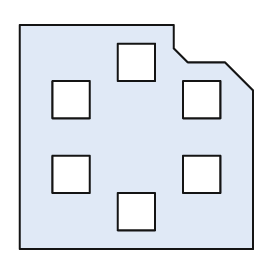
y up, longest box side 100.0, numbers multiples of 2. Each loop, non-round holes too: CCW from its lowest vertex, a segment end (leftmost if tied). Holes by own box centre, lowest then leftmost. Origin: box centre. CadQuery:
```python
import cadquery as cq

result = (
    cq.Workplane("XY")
    .moveTo(-50.0, -48.0)
    .lineTo(50.0, -48.0)
    .lineTo(50.0, 20.0)
    .lineTo(38.0, 32.0)
    .lineTo(22.0, 32.0)
    .lineTo(16.0, 38.0)
    .lineTo(16.0, 48.0)
    .lineTo(-50.0, 48.0)
    .close()
    .moveTo(-8.0, -40.0)
    .lineTo(8.0, -40.0)
    .lineTo(8.0, -24.0)
    .lineTo(-8.0, -24.0)
    .close()
    .moveTo(-36.0, -24.0)
    .lineTo(-20.0, -24.0)
    .lineTo(-20.0, -8.0)
    .lineTo(-36.0, -8.0)
    .close()
    .moveTo(20.0, -24.0)
    .lineTo(36.0, -24.0)
    .lineTo(36.0, -8.0)
    .lineTo(20.0, -8.0)
    .close()
    .moveTo(-36.0, 8.0)
    .lineTo(-20.0, 8.0)
    .lineTo(-20.0, 24.0)
    .lineTo(-36.0, 24.0)
    .close()
    .moveTo(20.0, 8.0)
    .lineTo(36.0, 8.0)
    .lineTo(36.0, 24.0)
    .lineTo(20.0, 24.0)
    .close()
    .moveTo(-8.0, 24.0)
    .lineTo(8.0, 24.0)
    .lineTo(8.0, 40.0)
    .lineTo(-8.0, 40.0)
    .close()
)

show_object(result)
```